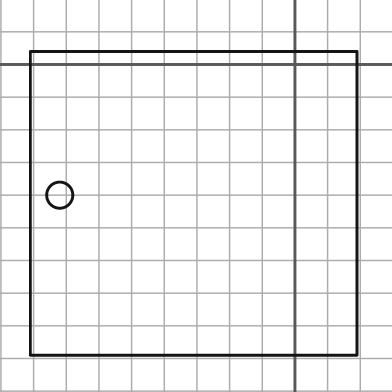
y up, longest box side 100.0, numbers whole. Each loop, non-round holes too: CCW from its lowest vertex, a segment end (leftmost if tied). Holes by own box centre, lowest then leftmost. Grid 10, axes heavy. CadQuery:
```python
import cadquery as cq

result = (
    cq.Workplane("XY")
    .moveTo(-81.0, -89.0)
    .lineTo(19.0, -89.0)
    .lineTo(19.0, 4.0)
    .lineTo(-81.0, 4.0)
    .close()
    .moveTo(-72.0, -40.0)
    .circle(4.0)
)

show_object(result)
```